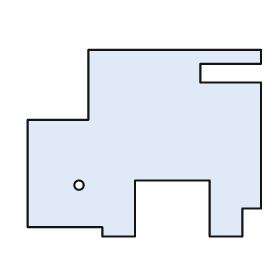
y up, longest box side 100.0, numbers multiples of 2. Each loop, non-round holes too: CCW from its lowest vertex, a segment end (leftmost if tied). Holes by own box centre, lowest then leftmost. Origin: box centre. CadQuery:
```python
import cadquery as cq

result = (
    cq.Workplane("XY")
    .moveTo(-18.0, -40.0)
    .lineTo(-4.0, -40.0)
    .lineTo(-4.0, -16.0)
    .lineTo(28.0, -16.0)
    .lineTo(28.0, -40.0)
    .lineTo(42.0, -40.0)
    .lineTo(42.0, -28.0)
    .lineTo(50.0, -28.0)
    .lineTo(50.0, 26.0)
    .lineTo(24.0, 26.0)
    .lineTo(24.0, 34.0)
    .lineTo(50.0, 34.0)
    .lineTo(50.0, 40.0)
    .lineTo(-24.0, 40.0)
    .lineTo(-24.0, 10.0)
    .lineTo(-50.0, 10.0)
    .lineTo(-50.0, -36.0)
    .lineTo(-18.0, -36.0)
    .close()
    .moveTo(-28.0, -18.0)
    .circle(2.0)
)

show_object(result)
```